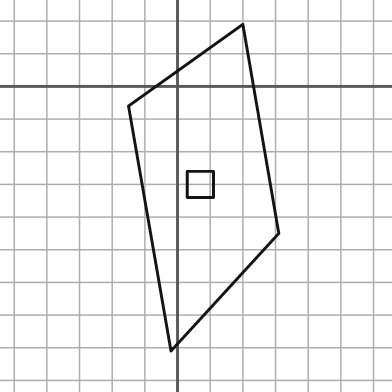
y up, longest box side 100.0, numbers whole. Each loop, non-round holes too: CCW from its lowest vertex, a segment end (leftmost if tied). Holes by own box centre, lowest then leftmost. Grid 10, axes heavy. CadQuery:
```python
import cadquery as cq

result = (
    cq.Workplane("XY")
    .moveTo(-2.0, -81.0)
    .lineTo(31.0, -45.0)
    .lineTo(20.0, 19.0)
    .lineTo(-15.0, -6.0)
    .close()
    .moveTo(3.0, -34.0)
    .lineTo(11.0, -34.0)
    .lineTo(11.0, -26.0)
    .lineTo(3.0, -26.0)
    .close()
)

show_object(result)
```